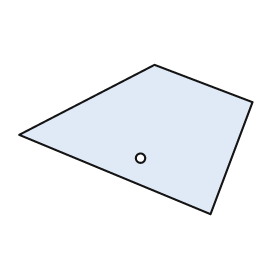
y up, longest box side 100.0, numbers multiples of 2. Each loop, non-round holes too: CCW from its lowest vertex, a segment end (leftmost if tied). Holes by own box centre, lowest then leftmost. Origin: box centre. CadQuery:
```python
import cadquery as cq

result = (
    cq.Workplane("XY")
    .moveTo(32.0, -32.0)
    .lineTo(50.0, 16.0)
    .lineTo(8.0, 32.0)
    .lineTo(-50.0, 2.0)
    .close()
    .moveTo(2.0, -8.0)
    .circle(2.0)
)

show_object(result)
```